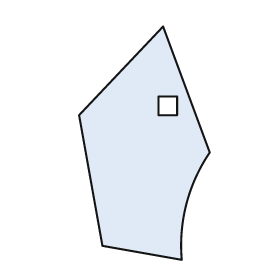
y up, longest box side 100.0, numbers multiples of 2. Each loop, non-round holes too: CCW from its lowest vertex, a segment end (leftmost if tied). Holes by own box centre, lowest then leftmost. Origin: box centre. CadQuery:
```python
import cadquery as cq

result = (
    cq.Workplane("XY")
    .moveTo(16.0, -50.0)
    .threePointArc((18.0, -26.0), (28.0, -4.0))
    .lineTo(8.0, 50.0)
    .lineTo(-28.0, 12.0)
    .lineTo(-18.0, -44.0)
    .close()
    .moveTo(6.0, 12.0)
    .lineTo(14.0, 12.0)
    .lineTo(14.0, 20.0)
    .lineTo(6.0, 20.0)
    .close()
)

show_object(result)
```